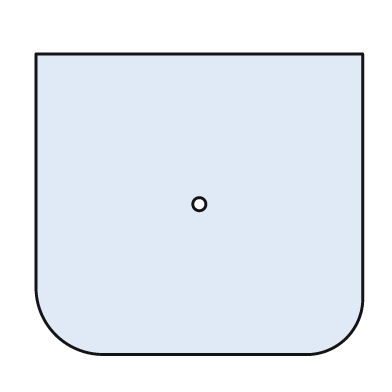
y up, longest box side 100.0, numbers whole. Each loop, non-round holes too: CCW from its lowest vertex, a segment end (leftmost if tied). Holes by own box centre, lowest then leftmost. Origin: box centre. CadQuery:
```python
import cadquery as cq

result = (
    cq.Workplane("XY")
    .moveTo(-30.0, -46.0)
    .lineTo(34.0, -46.0)
    .threePointArc((45.0, -41.0), (50.0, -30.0))
    .lineTo(50.0, 46.0)
    .lineTo(-50.0, 46.0)
    .lineTo(-50.0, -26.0)
    .threePointArc((-44.0, -40.0), (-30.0, -46.0))
    .close()
    .moveTo(0.0, 0.0)
    .circle(2.0)
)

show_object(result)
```